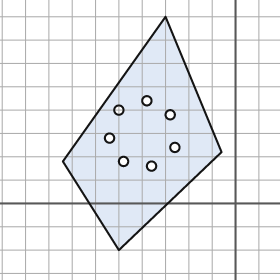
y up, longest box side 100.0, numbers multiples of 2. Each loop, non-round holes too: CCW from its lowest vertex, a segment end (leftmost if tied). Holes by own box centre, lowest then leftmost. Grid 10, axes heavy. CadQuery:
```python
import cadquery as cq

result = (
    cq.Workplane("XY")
    .moveTo(-50.0, -20.0)
    .lineTo(-6.0, 22.0)
    .lineTo(-30.0, 80.0)
    .lineTo(-74.0, 18.0)
    .close()
    .moveTo(-36.0, 16.0)
    .circle(2.0)
    .moveTo(-48.0, 18.0)
    .circle(2.0)
    .moveTo(-26.0, 24.0)
    .circle(2.0)
    .moveTo(-54.0, 28.0)
    .circle(2.0)
    .moveTo(-28.0, 38.0)
    .circle(2.0)
    .moveTo(-50.0, 40.0)
    .circle(2.0)
    .moveTo(-38.0, 44.0)
    .circle(2.0)
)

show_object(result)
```